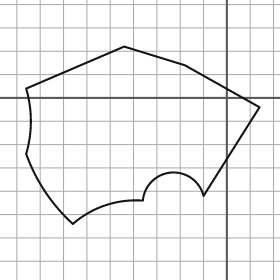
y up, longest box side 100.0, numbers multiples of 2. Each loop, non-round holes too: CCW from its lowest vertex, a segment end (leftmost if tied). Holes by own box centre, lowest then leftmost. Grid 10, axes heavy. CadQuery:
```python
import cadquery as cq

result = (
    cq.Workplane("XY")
    .moveTo(-66.0, -54.0)
    .threePointArc((-52.0, -46.0), (-36.0, -44.0))
    .threePointArc((-24.0, -32.0), (-10.0, -42.0))
    .lineTo(14.0, -4.0)
    .lineTo(-18.0, 14.0)
    .lineTo(-44.0, 22.0)
    .lineTo(-86.0, 4.0)
    .threePointArc((-84.0, -10.0), (-86.0, -24.0))
    .threePointArc((-78.0, -40.0), (-66.0, -54.0))
    .close()
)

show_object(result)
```